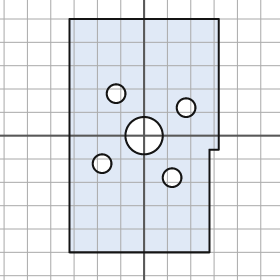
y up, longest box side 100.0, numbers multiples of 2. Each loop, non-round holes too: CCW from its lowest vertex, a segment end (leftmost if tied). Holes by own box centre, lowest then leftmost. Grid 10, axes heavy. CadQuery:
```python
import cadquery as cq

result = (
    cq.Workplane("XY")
    .moveTo(-32.0, -50.0)
    .lineTo(28.0, -50.0)
    .lineTo(28.0, -6.0)
    .lineTo(32.0, -6.0)
    .lineTo(32.0, 50.0)
    .lineTo(-32.0, 50.0)
    .close()
    .moveTo(12.0, -18.0)
    .circle(4.0)
    .moveTo(-18.0, -12.0)
    .circle(4.0)
    .moveTo(0.0, 0.0)
    .circle(8.0)
    .moveTo(18.0, 12.0)
    .circle(4.0)
    .moveTo(-12.0, 18.0)
    .circle(4.0)
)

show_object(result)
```